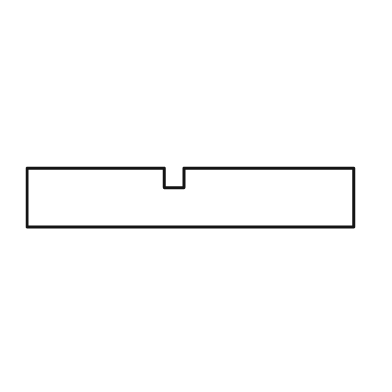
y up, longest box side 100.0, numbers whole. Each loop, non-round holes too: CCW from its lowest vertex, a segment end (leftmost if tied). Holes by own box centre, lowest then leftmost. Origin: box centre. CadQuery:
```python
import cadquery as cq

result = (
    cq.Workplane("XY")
    .moveTo(-50.0, -9.0)
    .lineTo(50.0, -9.0)
    .lineTo(50.0, 9.0)
    .lineTo(-2.0, 9.0)
    .lineTo(-2.0, 3.0)
    .lineTo(-8.0, 3.0)
    .lineTo(-8.0, 9.0)
    .lineTo(-50.0, 9.0)
    .close()
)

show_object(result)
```